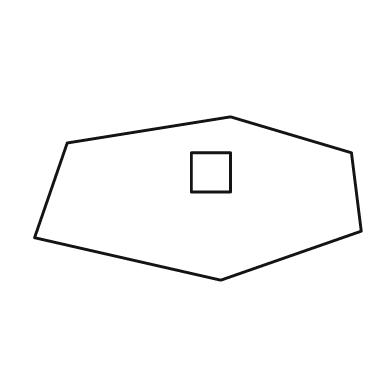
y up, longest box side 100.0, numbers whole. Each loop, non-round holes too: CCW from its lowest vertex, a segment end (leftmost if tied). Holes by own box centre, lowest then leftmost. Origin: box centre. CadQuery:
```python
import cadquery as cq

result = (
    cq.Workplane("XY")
    .moveTo(7.0, -25.0)
    .lineTo(50.0, -10.0)
    .lineTo(47.0, 14.0)
    .lineTo(10.0, 25.0)
    .lineTo(-40.0, 17.0)
    .lineTo(-50.0, -12.0)
    .close()
    .moveTo(-2.0, 2.0)
    .lineTo(10.0, 2.0)
    .lineTo(10.0, 14.0)
    .lineTo(-2.0, 14.0)
    .close()
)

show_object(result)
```